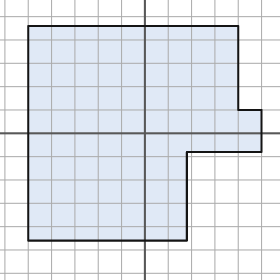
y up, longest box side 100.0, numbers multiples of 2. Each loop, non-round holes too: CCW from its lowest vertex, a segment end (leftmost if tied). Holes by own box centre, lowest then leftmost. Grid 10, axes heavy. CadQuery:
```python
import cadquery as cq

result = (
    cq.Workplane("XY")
    .moveTo(-50.0, -46.0)
    .lineTo(18.0, -46.0)
    .lineTo(18.0, -8.0)
    .lineTo(50.0, -8.0)
    .lineTo(50.0, 10.0)
    .lineTo(40.0, 10.0)
    .lineTo(40.0, 46.0)
    .lineTo(-50.0, 46.0)
    .close()
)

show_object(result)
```